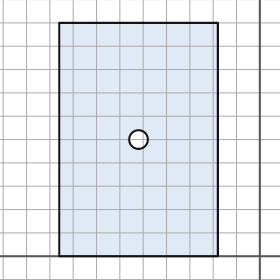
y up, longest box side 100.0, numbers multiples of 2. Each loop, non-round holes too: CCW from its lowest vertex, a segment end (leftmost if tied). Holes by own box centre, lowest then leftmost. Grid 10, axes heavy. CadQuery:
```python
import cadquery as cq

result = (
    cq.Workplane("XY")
    .moveTo(-86.0, 0.0)
    .lineTo(-18.0, 0.0)
    .lineTo(-18.0, 100.0)
    .lineTo(-86.0, 100.0)
    .close()
    .moveTo(-52.0, 50.0)
    .circle(4.0)
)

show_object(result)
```